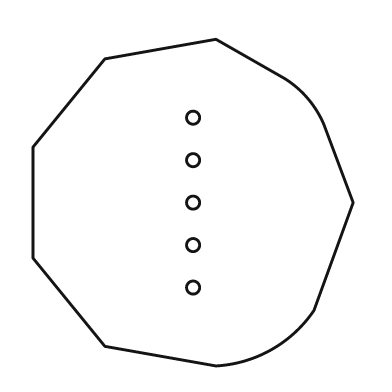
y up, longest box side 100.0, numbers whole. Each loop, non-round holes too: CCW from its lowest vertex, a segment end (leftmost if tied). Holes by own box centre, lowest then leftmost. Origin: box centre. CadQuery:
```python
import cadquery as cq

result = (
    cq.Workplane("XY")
    .moveTo(7.0, -50.0)
    .threePointArc((24.0, -45.0), (37.0, -33.0))
    .lineTo(49.0, 0.0)
    .lineTo(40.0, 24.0)
    .threePointArc((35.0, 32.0), (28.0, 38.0))
    .lineTo(7.0, 50.0)
    .lineTo(-27.0, 44.0)
    .lineTo(-49.0, 17.0)
    .lineTo(-49.0, -17.0)
    .lineTo(-27.0, -44.0)
    .close()
    .moveTo(0.0, -26.0)
    .circle(2.0)
    .moveTo(0.0, -13.0)
    .circle(2.0)
    .moveTo(0.0, 0.0)
    .circle(2.0)
    .moveTo(0.0, 13.0)
    .circle(2.0)
    .moveTo(0.0, 26.0)
    .circle(2.0)
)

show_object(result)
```